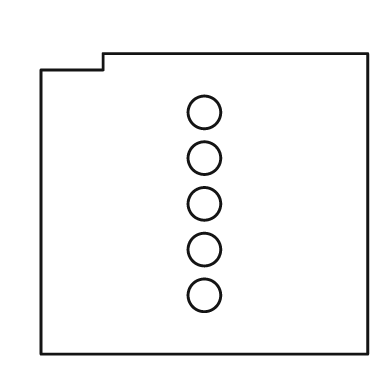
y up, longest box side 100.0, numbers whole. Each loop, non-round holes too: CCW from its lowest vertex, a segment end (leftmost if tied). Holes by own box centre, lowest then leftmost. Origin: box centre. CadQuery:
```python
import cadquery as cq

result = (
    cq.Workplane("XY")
    .moveTo(-50.0, -46.0)
    .lineTo(50.0, -46.0)
    .lineTo(50.0, 46.0)
    .lineTo(-31.0, 46.0)
    .lineTo(-31.0, 41.0)
    .lineTo(-50.0, 41.0)
    .close()
    .moveTo(0.0, -28.0)
    .circle(5.0)
    .moveTo(0.0, -14.0)
    .circle(5.0)
    .moveTo(0.0, 0.0)
    .circle(5.0)
    .moveTo(0.0, 14.0)
    .circle(5.0)
    .moveTo(0.0, 28.0)
    .circle(5.0)
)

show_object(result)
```